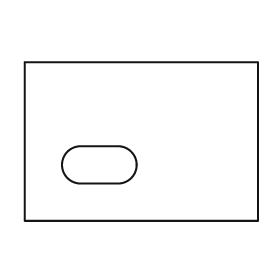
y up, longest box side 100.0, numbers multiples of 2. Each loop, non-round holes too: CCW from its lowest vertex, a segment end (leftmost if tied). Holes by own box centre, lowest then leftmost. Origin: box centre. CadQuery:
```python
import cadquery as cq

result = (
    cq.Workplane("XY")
    .moveTo(-50.0, -34.0)
    .lineTo(50.0, -34.0)
    .lineTo(50.0, 34.0)
    .lineTo(-50.0, 34.0)
    .close()
    .moveTo(-26.0, -18.0)
    .lineTo(-10.0, -18.0)
    .threePointArc((-2.0, -10.0), (-10.0, -2.0))
    .lineTo(-26.0, -2.0)
    .threePointArc((-34.0, -10.0), (-26.0, -18.0))
    .close()
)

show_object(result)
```